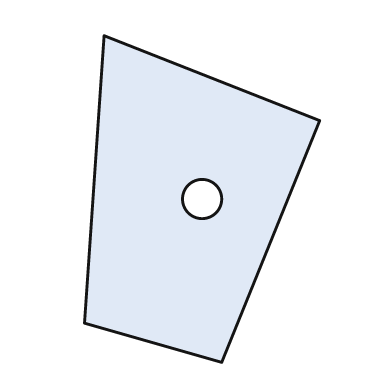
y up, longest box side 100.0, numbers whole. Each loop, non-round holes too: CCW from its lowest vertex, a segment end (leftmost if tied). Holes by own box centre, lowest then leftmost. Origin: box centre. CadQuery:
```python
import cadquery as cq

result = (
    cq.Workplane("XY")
    .moveTo(6.0, -50.0)
    .lineTo(36.0, 24.0)
    .lineTo(-30.0, 50.0)
    .lineTo(-36.0, -38.0)
    .close()
    .moveTo(0.0, 0.0)
    .circle(6.0)
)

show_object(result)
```